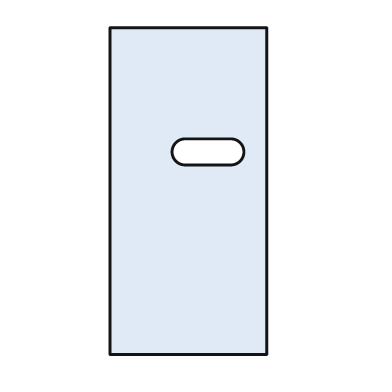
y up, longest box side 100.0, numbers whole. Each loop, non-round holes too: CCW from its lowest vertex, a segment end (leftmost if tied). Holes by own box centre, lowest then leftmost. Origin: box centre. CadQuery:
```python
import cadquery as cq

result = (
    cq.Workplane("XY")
    .moveTo(-24.0, -50.0)
    .lineTo(24.0, -50.0)
    .lineTo(24.0, 50.0)
    .lineTo(-24.0, 50.0)
    .close()
    .moveTo(-1.0, 8.0)
    .lineTo(13.0, 8.0)
    .threePointArc((17.0, 12.0), (13.0, 16.0))
    .lineTo(-1.0, 16.0)
    .threePointArc((-5.0, 12.0), (-1.0, 8.0))
    .close()
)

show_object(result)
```